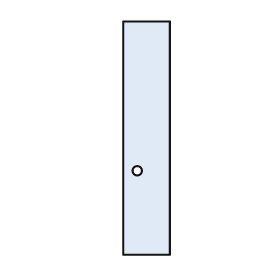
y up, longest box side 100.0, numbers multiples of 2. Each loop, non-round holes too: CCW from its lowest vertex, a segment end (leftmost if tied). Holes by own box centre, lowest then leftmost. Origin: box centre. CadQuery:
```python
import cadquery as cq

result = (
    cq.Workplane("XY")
    .moveTo(-10.0, -50.0)
    .lineTo(10.0, -50.0)
    .lineTo(10.0, 50.0)
    .lineTo(-10.0, 50.0)
    .close()
    .moveTo(-4.0, -14.0)
    .circle(2.0)
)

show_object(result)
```